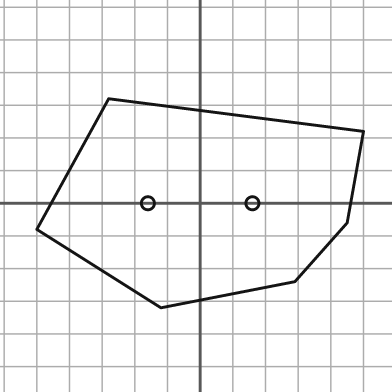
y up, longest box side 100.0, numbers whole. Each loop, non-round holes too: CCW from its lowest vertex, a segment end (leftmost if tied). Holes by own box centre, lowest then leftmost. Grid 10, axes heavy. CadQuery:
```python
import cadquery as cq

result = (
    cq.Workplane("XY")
    .moveTo(-12.0, -32.0)
    .lineTo(29.0, -24.0)
    .lineTo(45.0, -6.0)
    .lineTo(50.0, 22.0)
    .lineTo(-28.0, 32.0)
    .lineTo(-50.0, -8.0)
    .close()
    .moveTo(-16.0, 0.0)
    .circle(2.0)
    .moveTo(16.0, 0.0)
    .circle(2.0)
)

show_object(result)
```